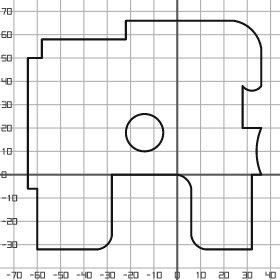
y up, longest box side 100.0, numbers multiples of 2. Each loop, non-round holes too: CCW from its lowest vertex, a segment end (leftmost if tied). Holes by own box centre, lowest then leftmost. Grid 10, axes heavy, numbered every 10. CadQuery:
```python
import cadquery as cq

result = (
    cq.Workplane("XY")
    .moveTo(-60.0, -32.0)
    .lineTo(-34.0, -32.0)
    .threePointArc((-30.0, -30.0), (-28.0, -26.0))
    .lineTo(-28.0, 0.0)
    .lineTo(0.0, 0.0)
    .threePointArc((4.0, -2.0), (6.0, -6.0))
    .lineTo(6.0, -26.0)
    .threePointArc((8.0, -30.0), (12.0, -32.0))
    .lineTo(32.0, -32.0)
    .lineTo(32.0, 0.0)
    .lineTo(36.0, 0.0)
    .threePointArc((34.0, 10.0), (36.0, 20.0))
    .lineTo(28.0, 20.0)
    .lineTo(28.0, 38.0)
    .threePointArc((32.0, 36.0), (36.0, 38.0))
    .lineTo(36.0, 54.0)
    .threePointArc((32.0, 62.0), (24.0, 66.0))
    .lineTo(-22.0, 66.0)
    .lineTo(-22.0, 58.0)
    .lineTo(-58.0, 58.0)
    .lineTo(-58.0, 50.0)
    .lineTo(-64.0, 50.0)
    .lineTo(-64.0, -6.0)
    .lineTo(-60.0, -6.0)
    .close()
    .moveTo(-14.0, 18.0)
    .circle(8.0)
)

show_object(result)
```